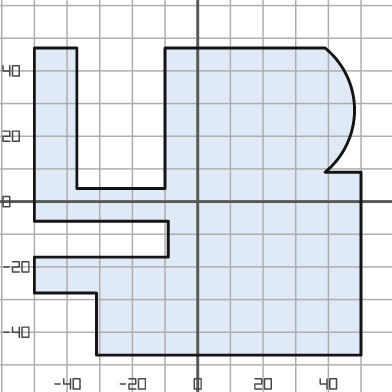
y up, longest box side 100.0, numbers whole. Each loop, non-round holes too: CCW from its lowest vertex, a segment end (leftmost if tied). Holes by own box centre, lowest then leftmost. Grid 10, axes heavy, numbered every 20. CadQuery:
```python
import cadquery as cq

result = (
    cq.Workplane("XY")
    .moveTo(-31.0, -47.0)
    .lineTo(50.0, -47.0)
    .lineTo(50.0, 9.0)
    .lineTo(39.0, 9.0)
    .threePointArc((48.0, 28.0), (39.0, 47.0))
    .lineTo(-10.0, 47.0)
    .lineTo(-10.0, 4.0)
    .lineTo(-37.0, 4.0)
    .lineTo(-37.0, 47.0)
    .lineTo(-50.0, 47.0)
    .lineTo(-50.0, -6.0)
    .lineTo(-9.0, -6.0)
    .lineTo(-9.0, -17.0)
    .lineTo(-50.0, -17.0)
    .lineTo(-50.0, -28.0)
    .lineTo(-31.0, -28.0)
    .close()
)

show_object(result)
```